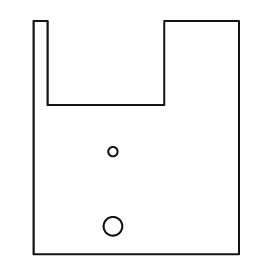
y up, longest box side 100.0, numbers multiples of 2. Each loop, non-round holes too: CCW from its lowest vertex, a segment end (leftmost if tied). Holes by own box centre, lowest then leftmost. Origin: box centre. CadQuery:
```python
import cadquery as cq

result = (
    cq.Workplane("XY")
    .moveTo(-44.0, -50.0)
    .lineTo(44.0, -50.0)
    .lineTo(44.0, 50.0)
    .lineTo(12.0, 50.0)
    .lineTo(12.0, 14.0)
    .lineTo(-38.0, 14.0)
    .lineTo(-38.0, 50.0)
    .lineTo(-44.0, 50.0)
    .close()
    .moveTo(-10.0, -38.0)
    .circle(4.0)
    .moveTo(-10.0, -6.0)
    .circle(2.0)
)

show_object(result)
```